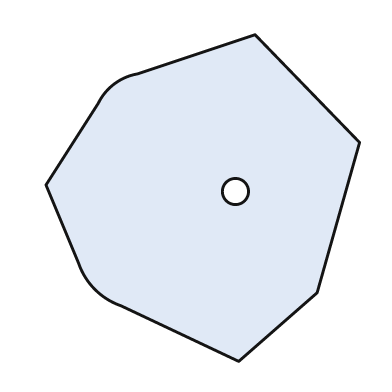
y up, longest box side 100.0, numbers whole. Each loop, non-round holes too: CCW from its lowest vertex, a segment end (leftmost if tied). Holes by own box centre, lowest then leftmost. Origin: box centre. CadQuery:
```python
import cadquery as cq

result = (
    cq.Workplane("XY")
    .moveTo(11.0, -50.0)
    .lineTo(35.0, -29.0)
    .lineTo(48.0, 17.0)
    .lineTo(16.0, 50.0)
    .lineTo(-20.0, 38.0)
    .threePointArc((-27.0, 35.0), (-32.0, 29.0))
    .lineTo(-48.0, 4.0)
    .lineTo(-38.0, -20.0)
    .threePointArc((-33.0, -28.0), (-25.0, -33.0))
    .close()
    .moveTo(10.0, 2.0)
    .circle(4.0)
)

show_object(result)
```